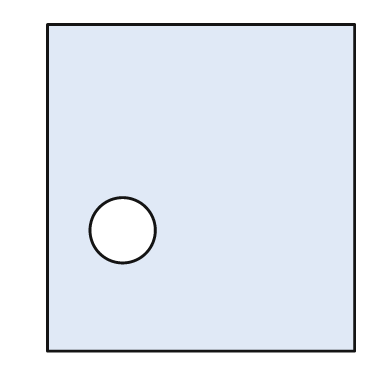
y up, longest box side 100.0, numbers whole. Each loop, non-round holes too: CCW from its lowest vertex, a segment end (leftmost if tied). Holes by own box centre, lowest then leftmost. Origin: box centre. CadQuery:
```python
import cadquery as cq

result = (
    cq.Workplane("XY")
    .moveTo(-47.0, -50.0)
    .lineTo(47.0, -50.0)
    .lineTo(47.0, 50.0)
    .lineTo(-47.0, 50.0)
    .close()
    .moveTo(-24.0, -13.0)
    .circle(10.0)
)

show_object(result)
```